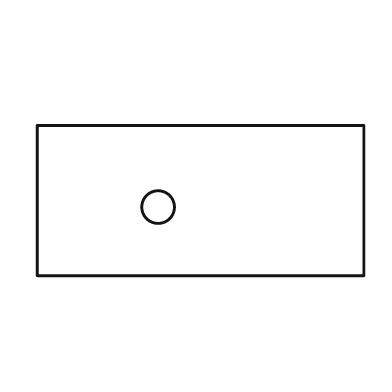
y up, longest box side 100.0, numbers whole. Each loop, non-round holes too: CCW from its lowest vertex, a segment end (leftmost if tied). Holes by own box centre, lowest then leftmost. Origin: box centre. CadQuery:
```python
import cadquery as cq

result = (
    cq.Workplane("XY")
    .moveTo(-50.0, -23.0)
    .lineTo(50.0, -23.0)
    .lineTo(50.0, 23.0)
    .lineTo(-50.0, 23.0)
    .close()
    .moveTo(-13.0, -2.0)
    .circle(5.0)
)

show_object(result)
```